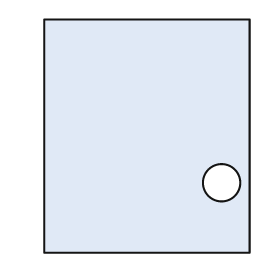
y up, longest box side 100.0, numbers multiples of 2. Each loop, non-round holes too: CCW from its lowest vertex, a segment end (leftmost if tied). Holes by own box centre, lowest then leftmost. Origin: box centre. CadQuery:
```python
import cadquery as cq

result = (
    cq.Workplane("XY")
    .moveTo(-44.0, -50.0)
    .lineTo(44.0, -50.0)
    .lineTo(44.0, 50.0)
    .lineTo(-44.0, 50.0)
    .close()
    .moveTo(32.0, -20.0)
    .circle(8.0)
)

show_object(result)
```